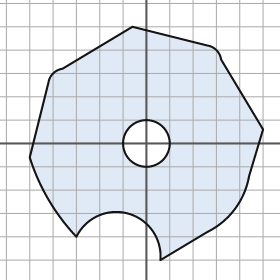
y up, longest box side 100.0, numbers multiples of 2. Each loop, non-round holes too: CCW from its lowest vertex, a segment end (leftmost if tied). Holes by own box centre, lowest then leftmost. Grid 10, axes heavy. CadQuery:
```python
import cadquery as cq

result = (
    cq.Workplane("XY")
    .moveTo(6.0, -50.0)
    .lineTo(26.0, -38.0)
    .threePointArc((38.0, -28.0), (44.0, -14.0))
    .lineTo(50.0, 6.0)
    .lineTo(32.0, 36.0)
    .threePointArc((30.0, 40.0), (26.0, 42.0))
    .lineTo(-6.0, 50.0)
    .lineTo(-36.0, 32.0)
    .threePointArc((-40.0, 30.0), (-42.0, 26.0))
    .lineTo(-50.0, -6.0)
    .threePointArc((-42.0, -24.0), (-30.0, -40.0))
    .threePointArc((-8.0, -30.0), (6.0, -50.0))
    .close()
    .moveTo(0.0, 0.0)
    .circle(10.0)
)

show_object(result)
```